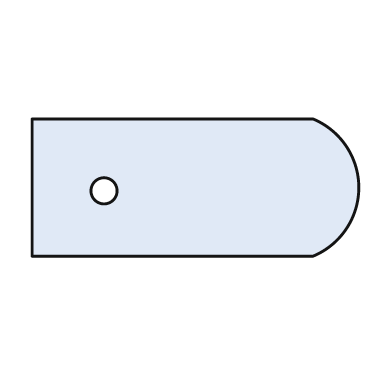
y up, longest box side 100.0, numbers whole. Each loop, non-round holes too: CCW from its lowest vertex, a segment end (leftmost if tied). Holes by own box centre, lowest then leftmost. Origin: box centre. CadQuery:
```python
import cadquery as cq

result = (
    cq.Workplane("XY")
    .moveTo(-50.0, -21.0)
    .lineTo(36.0, -21.0)
    .threePointArc((50.0, 0.0), (36.0, 21.0))
    .lineTo(-50.0, 21.0)
    .close()
    .moveTo(-28.0, -1.0)
    .circle(4.0)
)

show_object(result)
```